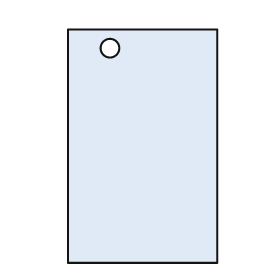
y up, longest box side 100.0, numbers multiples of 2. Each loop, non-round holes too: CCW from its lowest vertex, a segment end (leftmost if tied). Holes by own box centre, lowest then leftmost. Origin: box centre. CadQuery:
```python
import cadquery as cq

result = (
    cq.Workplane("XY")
    .moveTo(-32.0, -50.0)
    .lineTo(32.0, -50.0)
    .lineTo(32.0, 50.0)
    .lineTo(-32.0, 50.0)
    .close()
    .moveTo(-14.0, 42.0)
    .circle(4.0)
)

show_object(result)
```